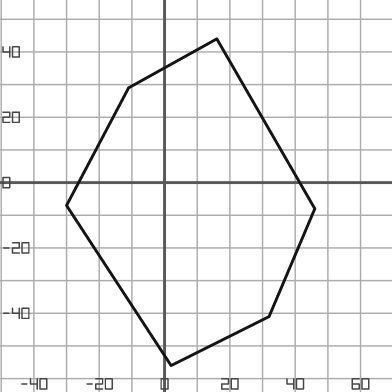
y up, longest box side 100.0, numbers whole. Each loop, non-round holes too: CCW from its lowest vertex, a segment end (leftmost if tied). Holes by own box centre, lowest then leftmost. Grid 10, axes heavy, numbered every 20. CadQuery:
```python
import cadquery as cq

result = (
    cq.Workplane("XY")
    .moveTo(2.0, -56.0)
    .lineTo(32.0, -41.0)
    .lineTo(46.0, -8.0)
    .lineTo(16.0, 44.0)
    .lineTo(-11.0, 29.0)
    .lineTo(-30.0, -7.0)
    .close()
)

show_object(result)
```